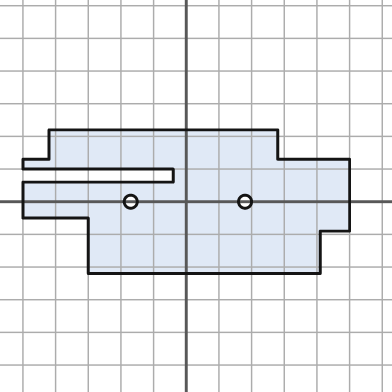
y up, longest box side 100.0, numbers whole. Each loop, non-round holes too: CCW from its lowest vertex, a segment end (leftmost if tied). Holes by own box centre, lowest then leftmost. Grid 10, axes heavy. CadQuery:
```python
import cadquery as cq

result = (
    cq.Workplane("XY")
    .moveTo(-30.0, -22.0)
    .lineTo(41.0, -22.0)
    .lineTo(41.0, -9.0)
    .lineTo(50.0, -9.0)
    .lineTo(50.0, 13.0)
    .lineTo(28.0, 13.0)
    .lineTo(28.0, 22.0)
    .lineTo(-42.0, 22.0)
    .lineTo(-42.0, 13.0)
    .lineTo(-50.0, 13.0)
    .lineTo(-50.0, 10.0)
    .lineTo(-4.0, 10.0)
    .lineTo(-4.0, 6.0)
    .lineTo(-50.0, 6.0)
    .lineTo(-50.0, -5.0)
    .lineTo(-30.0, -5.0)
    .close()
    .moveTo(-17.0, 0.0)
    .circle(2.0)
    .moveTo(18.0, 0.0)
    .circle(2.0)
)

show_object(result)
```